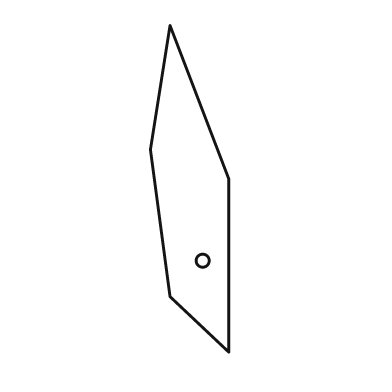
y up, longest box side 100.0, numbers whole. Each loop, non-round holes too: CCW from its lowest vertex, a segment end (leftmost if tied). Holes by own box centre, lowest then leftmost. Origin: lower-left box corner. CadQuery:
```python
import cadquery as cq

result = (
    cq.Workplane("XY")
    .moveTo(24.0, 0.0)
    .lineTo(24.0, 53.0)
    .lineTo(6.0, 100.0)
    .lineTo(0.0, 62.0)
    .lineTo(6.0, 17.0)
    .close()
    .moveTo(16.0, 28.0)
    .circle(2.0)
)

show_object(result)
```